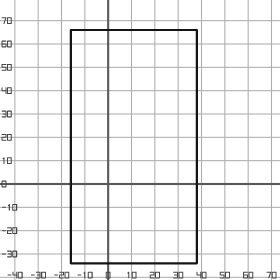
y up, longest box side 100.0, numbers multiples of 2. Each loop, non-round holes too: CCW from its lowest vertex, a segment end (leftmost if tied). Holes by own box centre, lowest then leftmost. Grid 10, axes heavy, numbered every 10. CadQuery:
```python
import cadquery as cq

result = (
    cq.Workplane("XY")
    .moveTo(-16.0, -34.0)
    .lineTo(38.0, -34.0)
    .lineTo(38.0, 66.0)
    .lineTo(-16.0, 66.0)
    .close()
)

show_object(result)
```